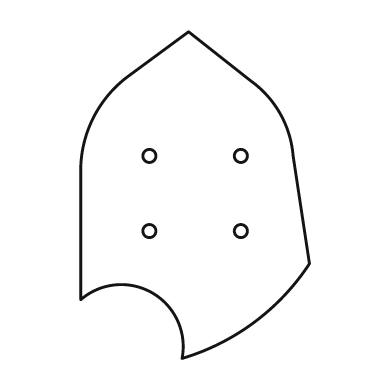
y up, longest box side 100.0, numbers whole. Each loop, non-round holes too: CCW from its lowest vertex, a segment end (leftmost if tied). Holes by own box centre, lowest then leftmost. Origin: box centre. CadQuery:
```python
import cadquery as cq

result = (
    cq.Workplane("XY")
    .moveTo(-4.0, -50.0)
    .threePointArc((18.0, -39.0), (35.0, -21.0))
    .lineTo(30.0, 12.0)
    .threePointArc((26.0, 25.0), (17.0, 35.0))
    .lineTo(-2.0, 50.0)
    .lineTo(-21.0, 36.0)
    .threePointArc((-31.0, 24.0), (-35.0, 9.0))
    .lineTo(-35.0, -32.0)
    .threePointArc((-13.0, -30.0), (-4.0, -50.0))
    .close()
    .moveTo(-14.0, -11.0)
    .circle(2.0)
    .moveTo(14.0, -11.0)
    .circle(2.0)
    .moveTo(-14.0, 12.0)
    .circle(2.0)
    .moveTo(14.0, 12.0)
    .circle(2.0)
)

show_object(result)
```